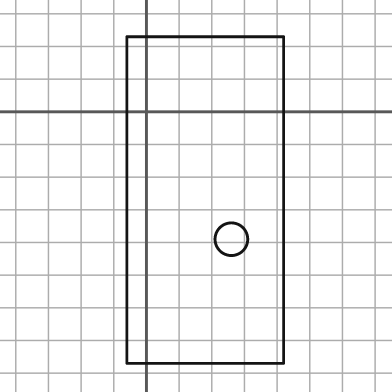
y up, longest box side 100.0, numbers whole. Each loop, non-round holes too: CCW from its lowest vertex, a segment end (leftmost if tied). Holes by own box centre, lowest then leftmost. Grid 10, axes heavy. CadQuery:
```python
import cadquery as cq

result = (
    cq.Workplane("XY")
    .moveTo(-6.0, -77.0)
    .lineTo(42.0, -77.0)
    .lineTo(42.0, 23.0)
    .lineTo(-6.0, 23.0)
    .close()
    .moveTo(26.0, -39.0)
    .circle(5.0)
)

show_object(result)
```